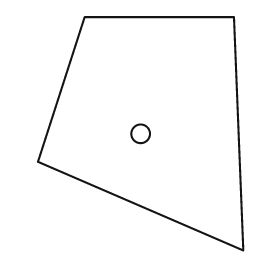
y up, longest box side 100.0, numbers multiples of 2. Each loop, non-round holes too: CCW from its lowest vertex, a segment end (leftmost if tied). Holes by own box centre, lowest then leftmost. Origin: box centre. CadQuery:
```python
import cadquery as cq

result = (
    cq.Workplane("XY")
    .moveTo(44.0, -50.0)
    .lineTo(40.0, 50.0)
    .lineTo(-24.0, 50.0)
    .lineTo(-44.0, -12.0)
    .close()
    .moveTo(0.0, 0.0)
    .circle(4.0)
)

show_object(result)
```